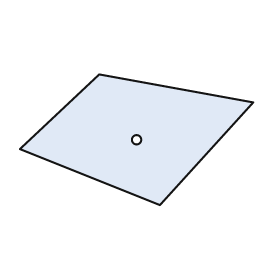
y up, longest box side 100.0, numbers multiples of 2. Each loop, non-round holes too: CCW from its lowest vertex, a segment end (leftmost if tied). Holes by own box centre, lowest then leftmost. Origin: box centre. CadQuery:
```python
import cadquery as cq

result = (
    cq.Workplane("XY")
    .moveTo(10.0, -28.0)
    .lineTo(50.0, 16.0)
    .lineTo(-16.0, 28.0)
    .lineTo(-50.0, -4.0)
    .close()
    .moveTo(0.0, 0.0)
    .circle(2.0)
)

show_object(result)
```